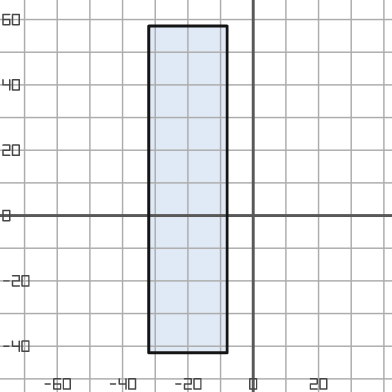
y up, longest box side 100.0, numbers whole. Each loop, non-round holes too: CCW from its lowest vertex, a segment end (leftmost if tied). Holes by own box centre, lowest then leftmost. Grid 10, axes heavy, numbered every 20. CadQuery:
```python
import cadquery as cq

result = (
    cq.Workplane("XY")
    .moveTo(-32.0, -42.0)
    .lineTo(-8.0, -42.0)
    .lineTo(-8.0, 58.0)
    .lineTo(-32.0, 58.0)
    .close()
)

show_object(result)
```